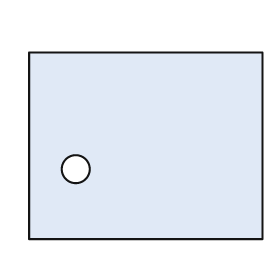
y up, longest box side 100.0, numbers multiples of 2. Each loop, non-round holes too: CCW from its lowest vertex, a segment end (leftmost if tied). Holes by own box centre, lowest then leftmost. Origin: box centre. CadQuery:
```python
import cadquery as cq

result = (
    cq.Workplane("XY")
    .moveTo(-50.0, -40.0)
    .lineTo(50.0, -40.0)
    .lineTo(50.0, 40.0)
    .lineTo(-50.0, 40.0)
    .close()
    .moveTo(-30.0, -10.0)
    .circle(6.0)
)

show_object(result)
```